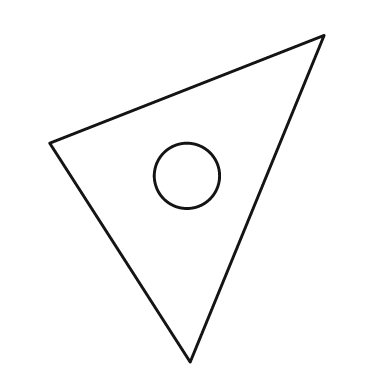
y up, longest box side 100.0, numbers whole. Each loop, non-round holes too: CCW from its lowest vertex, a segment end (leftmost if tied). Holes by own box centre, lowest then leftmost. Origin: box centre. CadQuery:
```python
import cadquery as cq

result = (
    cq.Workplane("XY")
    .moveTo(1.0, -50.0)
    .lineTo(42.0, 50.0)
    .lineTo(-42.0, 17.0)
    .close()
    .moveTo(0.0, 7.0)
    .circle(10.0)
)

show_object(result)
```